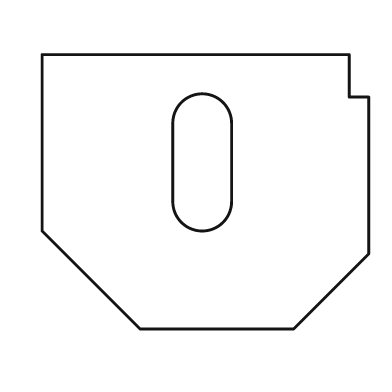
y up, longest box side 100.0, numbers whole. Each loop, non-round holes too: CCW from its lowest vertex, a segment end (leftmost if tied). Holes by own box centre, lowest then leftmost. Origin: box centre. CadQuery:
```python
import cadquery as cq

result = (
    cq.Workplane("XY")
    .moveTo(-20.0, -42.0)
    .lineTo(27.0, -42.0)
    .lineTo(50.0, -19.0)
    .lineTo(50.0, 29.0)
    .lineTo(44.0, 29.0)
    .lineTo(44.0, 42.0)
    .lineTo(-50.0, 42.0)
    .lineTo(-50.0, -12.0)
    .close()
    .moveTo(-10.0, -3.0)
    .threePointArc((-1.0, -12.0), (8.0, -3.0))
    .lineTo(8.0, 21.0)
    .threePointArc((-1.0, 30.0), (-10.0, 21.0))
    .close()
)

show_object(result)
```